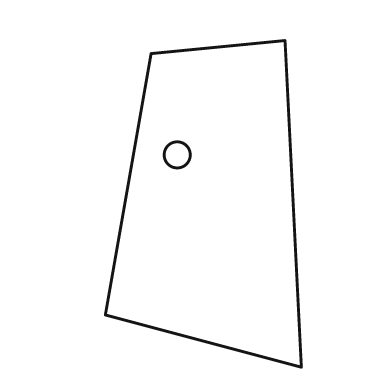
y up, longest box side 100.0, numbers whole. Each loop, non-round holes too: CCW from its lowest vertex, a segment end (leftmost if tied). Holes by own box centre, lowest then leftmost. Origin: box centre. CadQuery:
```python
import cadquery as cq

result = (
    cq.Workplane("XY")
    .moveTo(30.0, -50.0)
    .lineTo(25.0, 50.0)
    .lineTo(-16.0, 46.0)
    .lineTo(-30.0, -34.0)
    .close()
    .moveTo(-8.0, 15.0)
    .circle(4.0)
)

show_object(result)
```